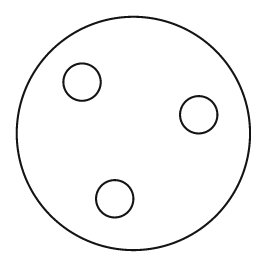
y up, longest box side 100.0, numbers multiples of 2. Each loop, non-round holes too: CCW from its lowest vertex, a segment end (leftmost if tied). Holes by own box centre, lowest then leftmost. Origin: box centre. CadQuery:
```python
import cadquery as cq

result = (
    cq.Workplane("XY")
    .moveTo(0.0, 0.0)
    .circle(50.0)
    .moveTo(-8.0, -28.0)
    .circle(8.0)
    .moveTo(28.0, 8.0)
    .circle(8.0)
    .moveTo(-22.0, 22.0)
    .circle(8.0)
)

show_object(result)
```